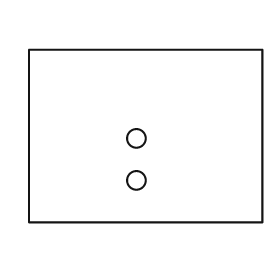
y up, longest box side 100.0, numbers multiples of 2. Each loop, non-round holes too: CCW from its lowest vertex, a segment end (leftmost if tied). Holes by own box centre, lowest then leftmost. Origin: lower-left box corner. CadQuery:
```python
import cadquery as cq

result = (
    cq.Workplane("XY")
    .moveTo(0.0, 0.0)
    .lineTo(100.0, 0.0)
    .lineTo(100.0, 74.0)
    .lineTo(0.0, 74.0)
    .close()
    .moveTo(46.0, 18.0)
    .circle(4.0)
    .moveTo(46.0, 36.0)
    .circle(4.0)
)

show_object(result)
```